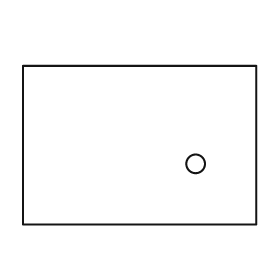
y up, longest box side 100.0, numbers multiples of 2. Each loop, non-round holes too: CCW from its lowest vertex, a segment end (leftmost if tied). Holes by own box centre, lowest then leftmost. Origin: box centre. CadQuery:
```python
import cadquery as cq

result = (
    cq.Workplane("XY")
    .moveTo(-50.0, -34.0)
    .lineTo(50.0, -34.0)
    .lineTo(50.0, 34.0)
    .lineTo(-50.0, 34.0)
    .close()
    .moveTo(24.0, -8.0)
    .circle(4.0)
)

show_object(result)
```